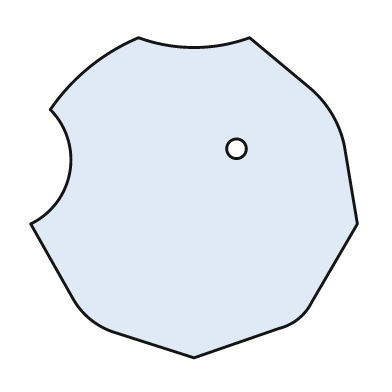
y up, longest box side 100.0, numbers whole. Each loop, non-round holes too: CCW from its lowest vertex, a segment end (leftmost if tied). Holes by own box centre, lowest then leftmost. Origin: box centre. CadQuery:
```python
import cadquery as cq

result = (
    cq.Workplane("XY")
    .moveTo(0.0, -49.0)
    .lineTo(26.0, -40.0)
    .threePointArc((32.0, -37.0), (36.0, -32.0))
    .lineTo(50.0, -8.0)
    .lineTo(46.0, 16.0)
    .threePointArc((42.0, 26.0), (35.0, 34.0))
    .lineTo(17.0, 49.0)
    .threePointArc((0.0, 46.0), (-17.0, 49.0))
    .threePointArc((-32.0, 40.0), (-44.0, 27.0))
    .threePointArc((-38.0, 8.0), (-50.0, -8.0))
    .lineTo(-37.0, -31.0)
    .threePointArc((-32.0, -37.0), (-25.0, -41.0))
    .close()
    .moveTo(13.0, 15.0)
    .circle(3.0)
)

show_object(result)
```